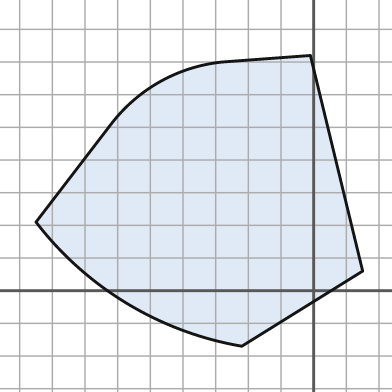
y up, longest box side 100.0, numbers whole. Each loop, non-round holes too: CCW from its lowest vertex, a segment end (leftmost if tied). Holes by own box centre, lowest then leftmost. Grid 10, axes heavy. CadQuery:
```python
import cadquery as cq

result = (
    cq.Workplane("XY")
    .moveTo(-22.0, -17.0)
    .lineTo(15.0, 6.0)
    .lineTo(-1.0, 72.0)
    .lineTo(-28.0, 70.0)
    .threePointArc((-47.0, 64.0), (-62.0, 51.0))
    .lineTo(-85.0, 21.0)
    .threePointArc((-57.0, -4.0), (-22.0, -17.0))
    .close()
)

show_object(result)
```